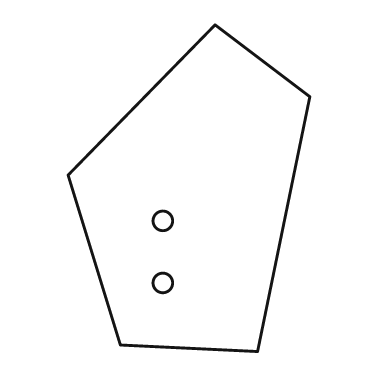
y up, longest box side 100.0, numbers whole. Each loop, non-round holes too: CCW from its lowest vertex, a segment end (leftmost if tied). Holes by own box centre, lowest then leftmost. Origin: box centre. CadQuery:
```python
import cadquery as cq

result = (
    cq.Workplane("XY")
    .moveTo(21.0, -50.0)
    .lineTo(37.0, 28.0)
    .lineTo(8.0, 50.0)
    .lineTo(-37.0, 4.0)
    .lineTo(-21.0, -48.0)
    .close()
    .moveTo(-8.0, -29.0)
    .circle(3.0)
    .moveTo(-8.0, -10.0)
    .circle(3.0)
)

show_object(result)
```